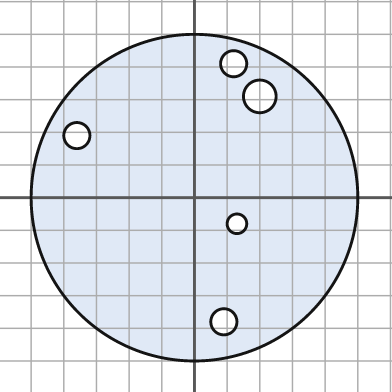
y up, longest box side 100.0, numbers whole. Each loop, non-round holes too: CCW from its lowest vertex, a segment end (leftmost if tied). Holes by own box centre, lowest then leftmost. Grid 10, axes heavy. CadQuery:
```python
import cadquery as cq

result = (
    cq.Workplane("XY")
    .moveTo(0.0, 0.0)
    .circle(50.0)
    .moveTo(9.0, -38.0)
    .circle(4.0)
    .moveTo(13.0, -8.0)
    .circle(3.0)
    .moveTo(-36.0, 19.0)
    .circle(4.0)
    .moveTo(20.0, 31.0)
    .circle(5.0)
    .moveTo(12.0, 41.0)
    .circle(4.0)
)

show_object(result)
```